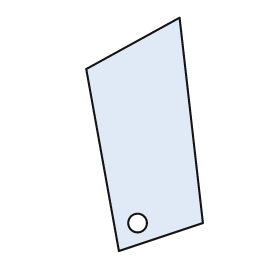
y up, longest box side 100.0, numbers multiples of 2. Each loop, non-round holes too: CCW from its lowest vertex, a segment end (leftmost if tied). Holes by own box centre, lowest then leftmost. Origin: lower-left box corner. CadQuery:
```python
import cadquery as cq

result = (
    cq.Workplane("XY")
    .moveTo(14.0, 0.0)
    .lineTo(50.0, 12.0)
    .lineTo(40.0, 100.0)
    .lineTo(0.0, 78.0)
    .close()
    .moveTo(22.0, 12.0)
    .circle(4.0)
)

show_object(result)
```